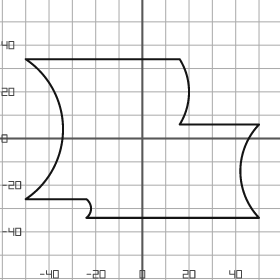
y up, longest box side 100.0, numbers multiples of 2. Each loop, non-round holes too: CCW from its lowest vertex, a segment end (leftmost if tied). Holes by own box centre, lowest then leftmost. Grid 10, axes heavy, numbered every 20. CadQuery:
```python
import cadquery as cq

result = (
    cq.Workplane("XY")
    .moveTo(-24.0, -34.0)
    .lineTo(50.0, -34.0)
    .threePointArc((42.0, -14.0), (50.0, 6.0))
    .lineTo(16.0, 6.0)
    .threePointArc((20.0, 20.0), (16.0, 34.0))
    .lineTo(-50.0, 34.0)
    .threePointArc((-34.0, 4.0), (-50.0, -26.0))
    .lineTo(-24.0, -26.0)
    .threePointArc((-22.0, -30.0), (-24.0, -34.0))
    .close()
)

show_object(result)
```